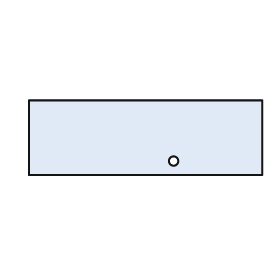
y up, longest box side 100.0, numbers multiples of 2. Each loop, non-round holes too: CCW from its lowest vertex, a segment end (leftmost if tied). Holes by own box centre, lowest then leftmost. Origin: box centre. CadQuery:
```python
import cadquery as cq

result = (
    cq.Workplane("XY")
    .moveTo(-50.0, -16.0)
    .lineTo(50.0, -16.0)
    .lineTo(50.0, 16.0)
    .lineTo(-50.0, 16.0)
    .close()
    .moveTo(12.0, -10.0)
    .circle(2.0)
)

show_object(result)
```